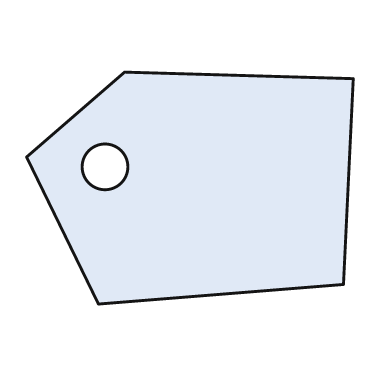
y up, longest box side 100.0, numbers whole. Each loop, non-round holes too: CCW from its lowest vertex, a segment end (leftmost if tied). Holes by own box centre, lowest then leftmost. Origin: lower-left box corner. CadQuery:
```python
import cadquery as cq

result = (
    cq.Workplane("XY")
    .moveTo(22.0, 0.0)
    .lineTo(97.0, 6.0)
    .lineTo(100.0, 69.0)
    .lineTo(30.0, 71.0)
    .lineTo(0.0, 45.0)
    .close()
    .moveTo(24.0, 42.0)
    .circle(7.0)
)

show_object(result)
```